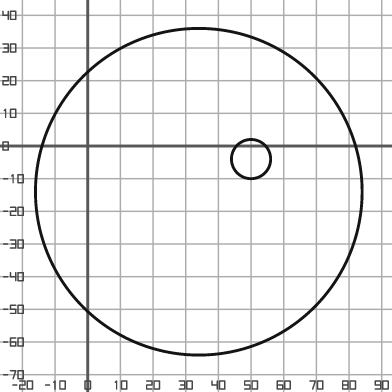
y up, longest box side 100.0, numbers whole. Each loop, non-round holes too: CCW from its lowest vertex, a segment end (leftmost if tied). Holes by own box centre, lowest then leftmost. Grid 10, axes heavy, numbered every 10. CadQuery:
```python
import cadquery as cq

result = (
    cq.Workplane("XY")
    .moveTo(34.0, -14.0)
    .circle(50.0)
    .moveTo(50.0, -4.0)
    .circle(6.0)
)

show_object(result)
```